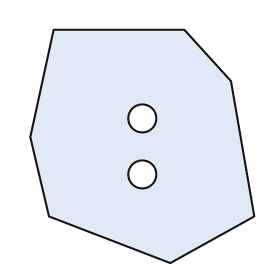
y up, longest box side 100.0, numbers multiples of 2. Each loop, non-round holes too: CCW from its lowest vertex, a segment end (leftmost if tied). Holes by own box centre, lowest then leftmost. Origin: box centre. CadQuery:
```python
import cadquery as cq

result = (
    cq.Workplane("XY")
    .moveTo(12.0, -50.0)
    .lineTo(48.0, -30.0)
    .lineTo(38.0, 28.0)
    .lineTo(18.0, 50.0)
    .lineTo(-38.0, 50.0)
    .lineTo(-48.0, 4.0)
    .lineTo(-40.0, -30.0)
    .close()
    .moveTo(0.0, -12.0)
    .circle(6.0)
    .moveTo(0.0, 12.0)
    .circle(6.0)
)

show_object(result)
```